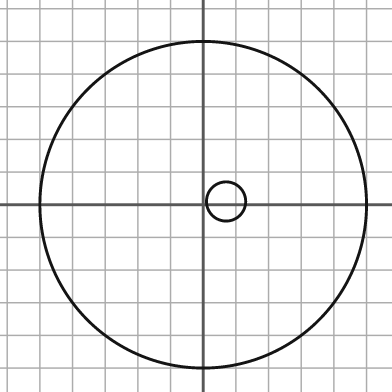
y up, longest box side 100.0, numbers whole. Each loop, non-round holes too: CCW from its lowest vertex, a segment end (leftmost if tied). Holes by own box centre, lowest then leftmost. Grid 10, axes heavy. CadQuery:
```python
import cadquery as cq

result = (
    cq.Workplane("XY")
    .moveTo(0.0, 0.0)
    .circle(50.0)
    .moveTo(7.0, 1.0)
    .circle(6.0)
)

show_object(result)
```